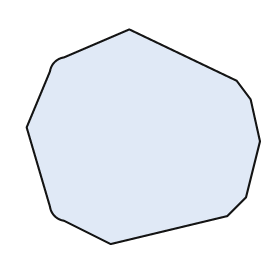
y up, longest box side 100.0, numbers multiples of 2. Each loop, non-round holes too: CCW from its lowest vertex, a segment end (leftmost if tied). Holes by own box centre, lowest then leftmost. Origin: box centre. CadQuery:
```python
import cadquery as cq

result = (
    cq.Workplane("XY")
    .moveTo(-14.0, -46.0)
    .lineTo(36.0, -34.0)
    .lineTo(44.0, -26.0)
    .lineTo(50.0, -2.0)
    .lineTo(46.0, 16.0)
    .lineTo(40.0, 24.0)
    .lineTo(-6.0, 46.0)
    .lineTo(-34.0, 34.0)
    .threePointArc((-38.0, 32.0), (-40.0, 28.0))
    .lineTo(-50.0, 4.0)
    .lineTo(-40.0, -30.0)
    .threePointArc((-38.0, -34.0), (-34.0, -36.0))
    .close()
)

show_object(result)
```